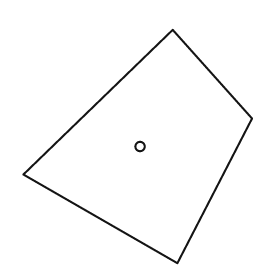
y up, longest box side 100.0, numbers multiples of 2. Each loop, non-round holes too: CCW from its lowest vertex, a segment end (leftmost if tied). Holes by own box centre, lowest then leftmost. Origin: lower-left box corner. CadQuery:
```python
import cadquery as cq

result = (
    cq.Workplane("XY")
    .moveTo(66.0, 0.0)
    .lineTo(98.0, 62.0)
    .lineTo(64.0, 100.0)
    .lineTo(0.0, 38.0)
    .close()
    .moveTo(50.0, 50.0)
    .circle(2.0)
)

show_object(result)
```